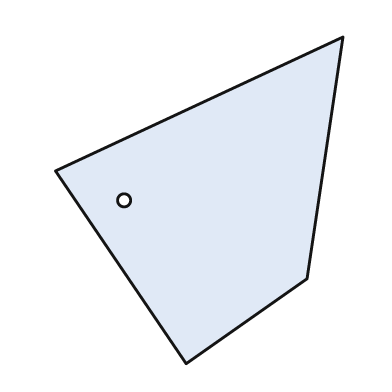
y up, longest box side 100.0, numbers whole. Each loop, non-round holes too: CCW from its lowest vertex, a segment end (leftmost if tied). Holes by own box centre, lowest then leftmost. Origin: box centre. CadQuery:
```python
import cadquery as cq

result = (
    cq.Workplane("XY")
    .moveTo(-4.0, -50.0)
    .lineTo(33.0, -24.0)
    .lineTo(44.0, 50.0)
    .lineTo(-44.0, 9.0)
    .close()
    .moveTo(-23.0, 0.0)
    .circle(2.0)
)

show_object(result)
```